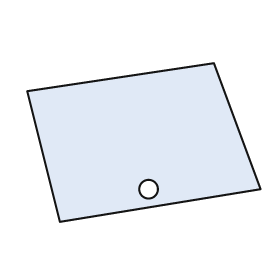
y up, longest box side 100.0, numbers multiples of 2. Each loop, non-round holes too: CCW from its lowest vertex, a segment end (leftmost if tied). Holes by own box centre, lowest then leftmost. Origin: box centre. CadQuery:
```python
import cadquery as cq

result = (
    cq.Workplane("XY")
    .moveTo(-36.0, -34.0)
    .lineTo(50.0, -20.0)
    .lineTo(30.0, 34.0)
    .lineTo(-50.0, 22.0)
    .close()
    .moveTo(2.0, -20.0)
    .circle(4.0)
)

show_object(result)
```